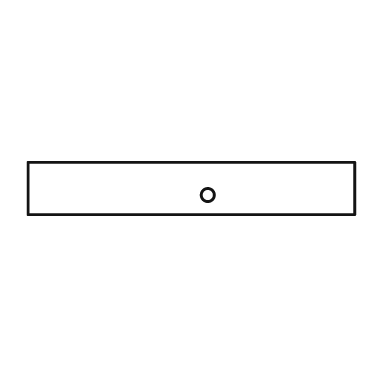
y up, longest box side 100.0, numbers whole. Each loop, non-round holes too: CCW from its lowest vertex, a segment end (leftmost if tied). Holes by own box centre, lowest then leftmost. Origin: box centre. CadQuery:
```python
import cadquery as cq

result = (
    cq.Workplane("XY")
    .moveTo(-50.0, -8.0)
    .lineTo(50.0, -8.0)
    .lineTo(50.0, 8.0)
    .lineTo(-50.0, 8.0)
    .close()
    .moveTo(5.0, -2.0)
    .circle(2.0)
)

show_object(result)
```